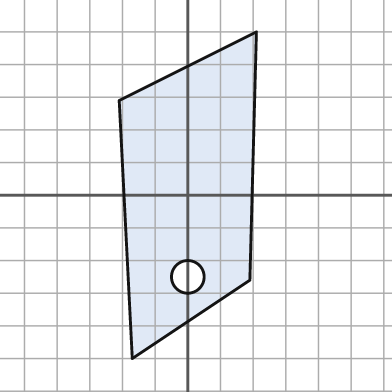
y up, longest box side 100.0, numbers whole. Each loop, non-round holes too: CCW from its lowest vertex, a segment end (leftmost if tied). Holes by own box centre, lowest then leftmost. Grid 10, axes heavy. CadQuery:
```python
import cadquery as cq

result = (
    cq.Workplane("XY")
    .moveTo(-17.0, -50.0)
    .lineTo(19.0, -26.0)
    .lineTo(21.0, 50.0)
    .lineTo(-21.0, 29.0)
    .close()
    .moveTo(0.0, -25.0)
    .circle(5.0)
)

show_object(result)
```